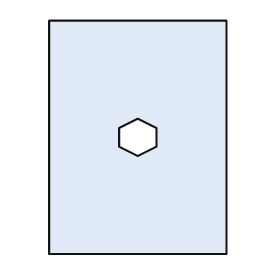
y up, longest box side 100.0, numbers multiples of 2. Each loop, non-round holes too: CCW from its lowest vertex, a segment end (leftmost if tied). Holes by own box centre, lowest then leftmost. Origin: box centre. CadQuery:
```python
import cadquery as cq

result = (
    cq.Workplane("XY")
    .moveTo(-38.0, -50.0)
    .lineTo(38.0, -50.0)
    .lineTo(38.0, 50.0)
    .lineTo(-38.0, 50.0)
    .close()
    .moveTo(0.0, -8.0)
    .lineTo(8.0, -4.0)
    .lineTo(8.0, 4.0)
    .lineTo(0.0, 8.0)
    .lineTo(-8.0, 4.0)
    .lineTo(-8.0, -4.0)
    .close()
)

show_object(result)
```